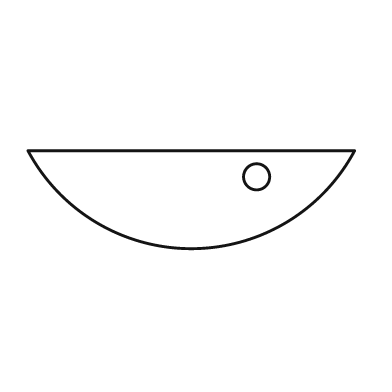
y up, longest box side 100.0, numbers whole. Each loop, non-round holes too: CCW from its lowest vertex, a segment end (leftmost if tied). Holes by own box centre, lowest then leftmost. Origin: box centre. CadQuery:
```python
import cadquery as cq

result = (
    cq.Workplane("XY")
    .moveTo(-50.0, 15.0)
    .threePointArc((0.0, -15.0), (50.0, 15.0))
    .close()
    .moveTo(20.0, 7.0)
    .circle(4.0)
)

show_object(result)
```